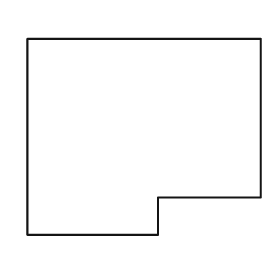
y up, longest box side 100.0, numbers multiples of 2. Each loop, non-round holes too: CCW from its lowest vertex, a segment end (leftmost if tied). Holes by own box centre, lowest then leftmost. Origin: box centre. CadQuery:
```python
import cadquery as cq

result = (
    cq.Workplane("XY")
    .moveTo(-50.0, -42.0)
    .lineTo(6.0, -42.0)
    .lineTo(6.0, -26.0)
    .lineTo(50.0, -26.0)
    .lineTo(50.0, 42.0)
    .lineTo(-50.0, 42.0)
    .close()
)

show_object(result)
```